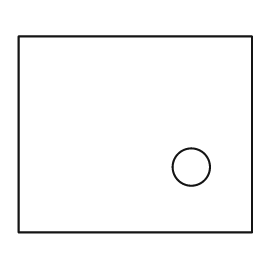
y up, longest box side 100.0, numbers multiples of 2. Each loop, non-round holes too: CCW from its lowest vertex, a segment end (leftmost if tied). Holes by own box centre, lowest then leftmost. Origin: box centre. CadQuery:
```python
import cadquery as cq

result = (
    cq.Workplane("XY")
    .moveTo(-50.0, -42.0)
    .lineTo(50.0, -42.0)
    .lineTo(50.0, 42.0)
    .lineTo(-50.0, 42.0)
    .close()
    .moveTo(24.0, -14.0)
    .circle(8.0)
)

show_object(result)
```